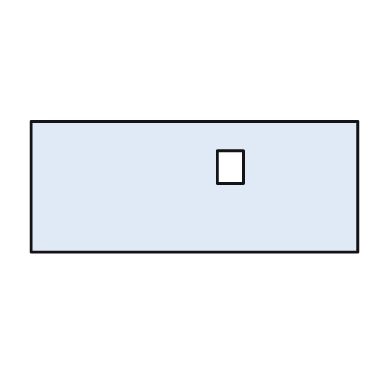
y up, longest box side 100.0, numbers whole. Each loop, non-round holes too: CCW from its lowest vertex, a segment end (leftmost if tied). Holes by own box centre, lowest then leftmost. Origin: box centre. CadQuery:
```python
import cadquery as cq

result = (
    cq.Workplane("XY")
    .moveTo(-50.0, -20.0)
    .lineTo(50.0, -20.0)
    .lineTo(50.0, 20.0)
    .lineTo(-50.0, 20.0)
    .close()
    .moveTo(7.0, 1.0)
    .lineTo(15.0, 1.0)
    .lineTo(15.0, 11.0)
    .lineTo(7.0, 11.0)
    .close()
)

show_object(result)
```